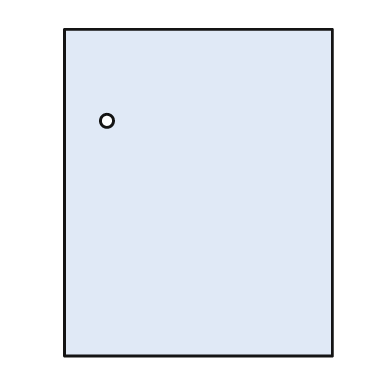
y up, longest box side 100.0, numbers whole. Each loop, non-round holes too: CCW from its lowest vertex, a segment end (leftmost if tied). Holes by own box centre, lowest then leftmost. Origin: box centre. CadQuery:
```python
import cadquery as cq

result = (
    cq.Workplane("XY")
    .moveTo(-41.0, -50.0)
    .lineTo(41.0, -50.0)
    .lineTo(41.0, 50.0)
    .lineTo(-41.0, 50.0)
    .close()
    .moveTo(-28.0, 22.0)
    .circle(2.0)
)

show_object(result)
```